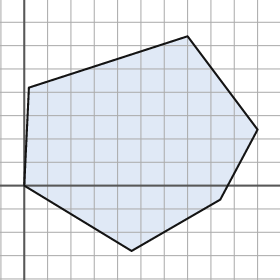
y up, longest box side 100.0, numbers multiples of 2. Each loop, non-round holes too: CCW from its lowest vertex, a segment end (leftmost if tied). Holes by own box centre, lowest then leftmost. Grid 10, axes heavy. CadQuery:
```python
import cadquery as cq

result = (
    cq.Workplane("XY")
    .moveTo(46.0, -28.0)
    .lineTo(84.0, -6.0)
    .lineTo(100.0, 24.0)
    .lineTo(70.0, 64.0)
    .lineTo(2.0, 42.0)
    .lineTo(0.0, 0.0)
    .close()
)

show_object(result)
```